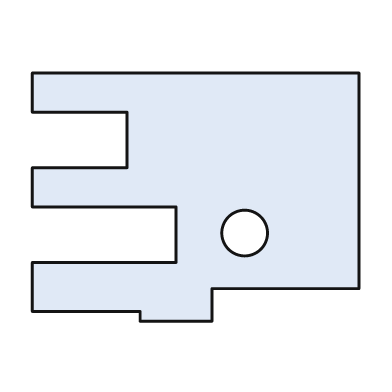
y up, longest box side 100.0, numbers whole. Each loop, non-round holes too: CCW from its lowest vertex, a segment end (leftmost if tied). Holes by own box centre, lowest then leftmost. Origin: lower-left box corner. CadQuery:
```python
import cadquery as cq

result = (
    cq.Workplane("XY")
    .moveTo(33.0, 0.0)
    .lineTo(55.0, 0.0)
    .lineTo(55.0, 10.0)
    .lineTo(100.0, 10.0)
    .lineTo(100.0, 76.0)
    .lineTo(0.0, 76.0)
    .lineTo(0.0, 64.0)
    .lineTo(29.0, 64.0)
    .lineTo(29.0, 47.0)
    .lineTo(0.0, 47.0)
    .lineTo(0.0, 35.0)
    .lineTo(44.0, 35.0)
    .lineTo(44.0, 18.0)
    .lineTo(0.0, 18.0)
    .lineTo(0.0, 3.0)
    .lineTo(33.0, 3.0)
    .close()
    .moveTo(65.0, 27.0)
    .circle(7.0)
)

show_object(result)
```